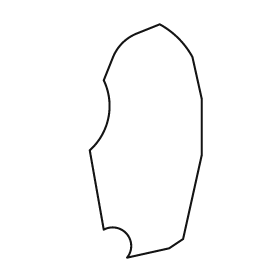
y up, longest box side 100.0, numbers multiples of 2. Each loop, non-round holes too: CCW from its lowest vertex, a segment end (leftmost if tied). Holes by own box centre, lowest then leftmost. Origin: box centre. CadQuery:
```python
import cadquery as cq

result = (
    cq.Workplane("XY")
    .moveTo(-8.0, -50.0)
    .lineTo(10.0, -46.0)
    .lineTo(16.0, -42.0)
    .lineTo(24.0, -6.0)
    .lineTo(24.0, 18.0)
    .lineTo(20.0, 36.0)
    .threePointArc((14.0, 44.0), (6.0, 50.0))
    .lineTo(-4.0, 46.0)
    .threePointArc((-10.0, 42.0), (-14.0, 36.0))
    .lineTo(-18.0, 26.0)
    .threePointArc((-16.0, 10.0), (-24.0, -4.0))
    .lineTo(-18.0, -38.0)
    .threePointArc((-8.0, -40.0), (-8.0, -50.0))
    .close()
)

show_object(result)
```